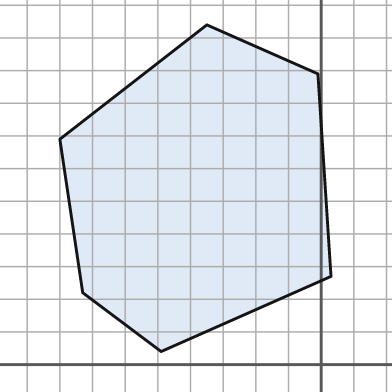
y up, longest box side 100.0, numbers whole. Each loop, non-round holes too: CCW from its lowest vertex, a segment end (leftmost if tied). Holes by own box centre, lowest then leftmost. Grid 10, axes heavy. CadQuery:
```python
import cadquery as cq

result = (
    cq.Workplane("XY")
    .moveTo(-49.0, 4.0)
    .lineTo(3.0, 27.0)
    .lineTo(-1.0, 89.0)
    .lineTo(-35.0, 104.0)
    .lineTo(-80.0, 69.0)
    .lineTo(-73.0, 22.0)
    .close()
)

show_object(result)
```